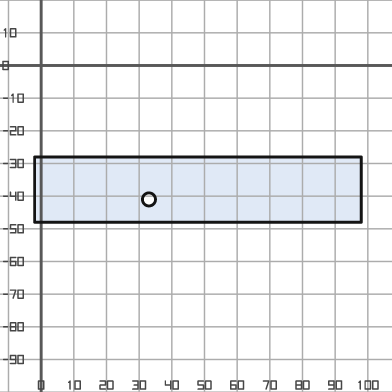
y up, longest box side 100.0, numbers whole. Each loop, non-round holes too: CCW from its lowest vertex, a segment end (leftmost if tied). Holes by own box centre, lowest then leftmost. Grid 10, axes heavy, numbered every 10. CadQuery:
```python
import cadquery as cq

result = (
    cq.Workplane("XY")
    .moveTo(-2.0, -48.0)
    .lineTo(98.0, -48.0)
    .lineTo(98.0, -28.0)
    .lineTo(-2.0, -28.0)
    .close()
    .moveTo(33.0, -41.0)
    .circle(2.0)
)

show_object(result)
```